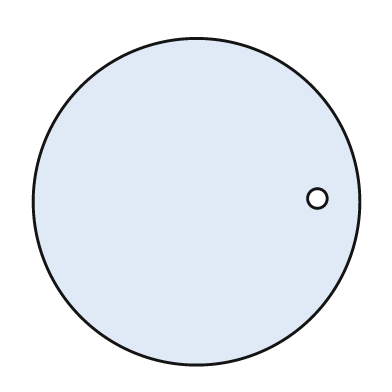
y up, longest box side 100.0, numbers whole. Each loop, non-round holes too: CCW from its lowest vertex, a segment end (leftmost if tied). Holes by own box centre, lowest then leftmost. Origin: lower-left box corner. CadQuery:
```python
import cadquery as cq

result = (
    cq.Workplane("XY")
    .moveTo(50.0, 50.0)
    .circle(50.0)
    .moveTo(87.0, 51.0)
    .circle(3.0)
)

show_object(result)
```